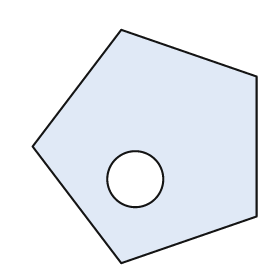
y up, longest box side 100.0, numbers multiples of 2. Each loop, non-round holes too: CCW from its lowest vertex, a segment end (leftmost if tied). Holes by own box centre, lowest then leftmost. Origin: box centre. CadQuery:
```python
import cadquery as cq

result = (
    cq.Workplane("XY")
    .moveTo(-10.0, -50.0)
    .lineTo(48.0, -30.0)
    .lineTo(48.0, 30.0)
    .lineTo(-10.0, 50.0)
    .lineTo(-48.0, 0.0)
    .close()
    .moveTo(-4.0, -14.0)
    .circle(12.0)
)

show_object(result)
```